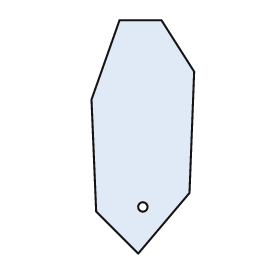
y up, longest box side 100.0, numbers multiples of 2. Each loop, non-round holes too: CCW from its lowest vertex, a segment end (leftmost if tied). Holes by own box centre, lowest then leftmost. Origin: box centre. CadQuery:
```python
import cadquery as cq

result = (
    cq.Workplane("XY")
    .moveTo(-2.0, -50.0)
    .lineTo(20.0, -24.0)
    .lineTo(22.0, 28.0)
    .lineTo(8.0, 50.0)
    .lineTo(-10.0, 50.0)
    .lineTo(-22.0, 16.0)
    .lineTo(-20.0, -32.0)
    .close()
    .moveTo(0.0, -30.0)
    .circle(2.0)
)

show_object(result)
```